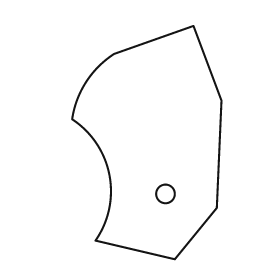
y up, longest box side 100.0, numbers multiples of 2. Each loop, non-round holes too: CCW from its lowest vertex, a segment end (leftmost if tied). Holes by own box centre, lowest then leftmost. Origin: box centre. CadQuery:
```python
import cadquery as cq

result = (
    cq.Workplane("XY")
    .moveTo(12.0, -50.0)
    .lineTo(30.0, -28.0)
    .lineTo(32.0, 18.0)
    .lineTo(20.0, 50.0)
    .lineTo(-14.0, 38.0)
    .threePointArc((-26.0, 26.0), (-32.0, 10.0))
    .threePointArc((-16.0, -14.0), (-22.0, -42.0))
    .close()
    .moveTo(8.0, -22.0)
    .circle(4.0)
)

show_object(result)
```